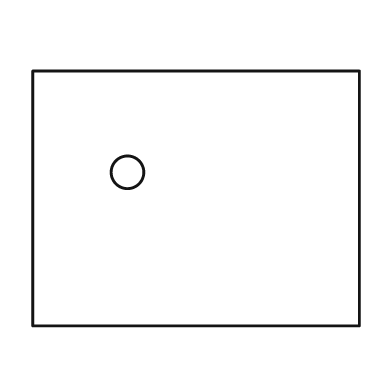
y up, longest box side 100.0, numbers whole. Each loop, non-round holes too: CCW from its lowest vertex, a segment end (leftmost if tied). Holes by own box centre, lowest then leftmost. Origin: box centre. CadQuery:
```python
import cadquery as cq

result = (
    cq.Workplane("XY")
    .moveTo(-50.0, -39.0)
    .lineTo(50.0, -39.0)
    .lineTo(50.0, 39.0)
    .lineTo(-50.0, 39.0)
    .close()
    .moveTo(-21.0, 8.0)
    .circle(5.0)
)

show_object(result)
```